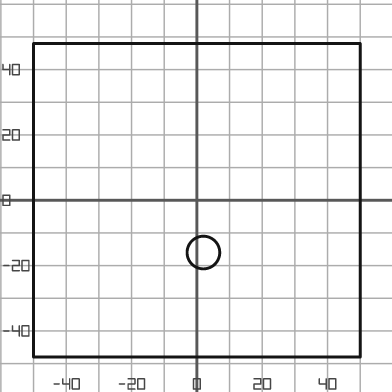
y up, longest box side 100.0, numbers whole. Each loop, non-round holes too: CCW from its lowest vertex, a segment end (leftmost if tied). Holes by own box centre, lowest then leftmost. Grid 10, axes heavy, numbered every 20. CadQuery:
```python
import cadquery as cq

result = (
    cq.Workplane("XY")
    .moveTo(-50.0, -48.0)
    .lineTo(50.0, -48.0)
    .lineTo(50.0, 48.0)
    .lineTo(-50.0, 48.0)
    .close()
    .moveTo(2.0, -16.0)
    .circle(5.0)
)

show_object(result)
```